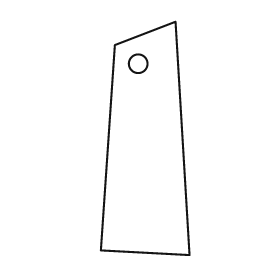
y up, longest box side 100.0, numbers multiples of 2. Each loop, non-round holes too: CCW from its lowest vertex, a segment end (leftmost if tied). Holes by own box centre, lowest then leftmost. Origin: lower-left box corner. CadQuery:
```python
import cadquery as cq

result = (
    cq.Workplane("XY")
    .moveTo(38.0, 0.0)
    .lineTo(32.0, 100.0)
    .lineTo(6.0, 90.0)
    .lineTo(0.0, 2.0)
    .close()
    .moveTo(16.0, 82.0)
    .circle(4.0)
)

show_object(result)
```